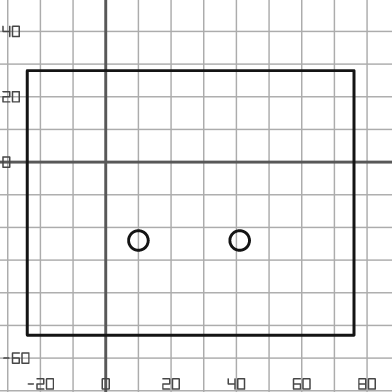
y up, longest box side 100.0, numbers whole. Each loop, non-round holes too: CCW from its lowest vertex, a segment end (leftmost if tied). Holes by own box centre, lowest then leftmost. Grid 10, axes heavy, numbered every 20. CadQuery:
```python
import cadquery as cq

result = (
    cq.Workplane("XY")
    .moveTo(-24.0, -53.0)
    .lineTo(76.0, -53.0)
    .lineTo(76.0, 28.0)
    .lineTo(-24.0, 28.0)
    .close()
    .moveTo(10.0, -24.0)
    .circle(3.0)
    .moveTo(41.0, -24.0)
    .circle(3.0)
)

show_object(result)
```